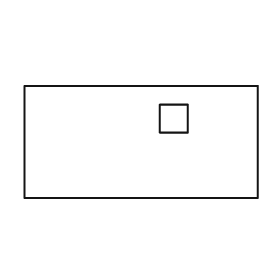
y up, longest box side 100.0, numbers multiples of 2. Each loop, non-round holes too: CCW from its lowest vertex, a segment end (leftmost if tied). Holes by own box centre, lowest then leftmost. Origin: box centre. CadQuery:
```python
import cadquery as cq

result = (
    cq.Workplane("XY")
    .moveTo(-50.0, -24.0)
    .lineTo(50.0, -24.0)
    .lineTo(50.0, 24.0)
    .lineTo(-50.0, 24.0)
    .close()
    .moveTo(8.0, 4.0)
    .lineTo(20.0, 4.0)
    .lineTo(20.0, 16.0)
    .lineTo(8.0, 16.0)
    .close()
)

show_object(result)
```